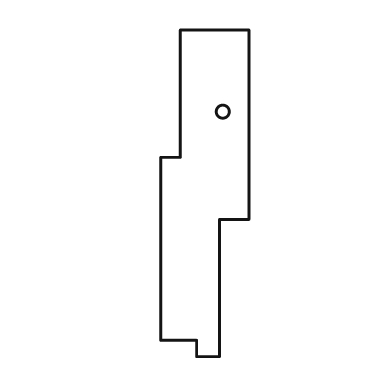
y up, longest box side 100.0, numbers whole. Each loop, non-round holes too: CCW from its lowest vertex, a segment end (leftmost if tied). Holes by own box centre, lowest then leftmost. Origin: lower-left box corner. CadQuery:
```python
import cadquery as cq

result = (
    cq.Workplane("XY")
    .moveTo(11.0, 0.0)
    .lineTo(18.0, 0.0)
    .lineTo(18.0, 42.0)
    .lineTo(27.0, 42.0)
    .lineTo(27.0, 100.0)
    .lineTo(6.0, 100.0)
    .lineTo(6.0, 61.0)
    .lineTo(0.0, 61.0)
    .lineTo(0.0, 5.0)
    .lineTo(11.0, 5.0)
    .close()
    .moveTo(19.0, 75.0)
    .circle(2.0)
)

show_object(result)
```